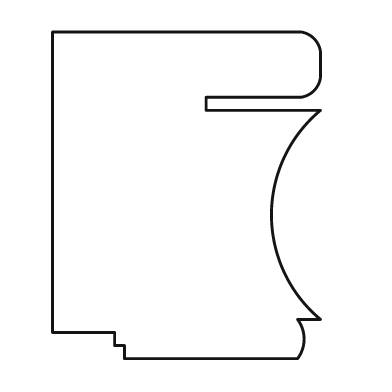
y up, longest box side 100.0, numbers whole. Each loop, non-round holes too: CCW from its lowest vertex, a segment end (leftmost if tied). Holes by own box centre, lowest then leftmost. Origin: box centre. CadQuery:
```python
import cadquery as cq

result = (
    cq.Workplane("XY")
    .moveTo(-19.0, -50.0)
    .lineTo(34.0, -50.0)
    .threePointArc((36.0, -44.0), (34.0, -38.0))
    .lineTo(41.0, -38.0)
    .threePointArc((26.0, -6.0), (41.0, 26.0))
    .lineTo(6.0, 26.0)
    .lineTo(6.0, 30.0)
    .lineTo(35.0, 30.0)
    .threePointArc((39.0, 32.0), (41.0, 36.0))
    .lineTo(41.0, 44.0)
    .threePointArc((39.0, 48.0), (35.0, 50.0))
    .lineTo(-41.0, 50.0)
    .lineTo(-41.0, -42.0)
    .lineTo(-22.0, -42.0)
    .lineTo(-22.0, -46.0)
    .lineTo(-19.0, -46.0)
    .close()
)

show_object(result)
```